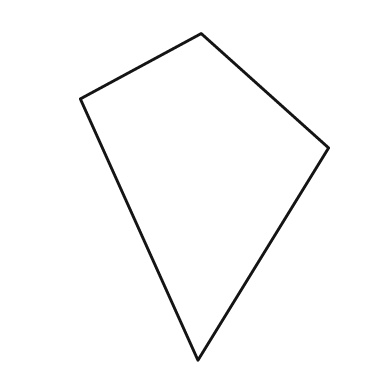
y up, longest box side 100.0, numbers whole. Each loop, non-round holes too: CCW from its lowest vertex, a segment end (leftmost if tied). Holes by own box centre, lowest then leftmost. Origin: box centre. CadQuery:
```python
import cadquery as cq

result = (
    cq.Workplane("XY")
    .moveTo(-2.0, -50.0)
    .lineTo(38.0, 15.0)
    .lineTo(-1.0, 50.0)
    .lineTo(-38.0, 30.0)
    .close()
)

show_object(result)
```